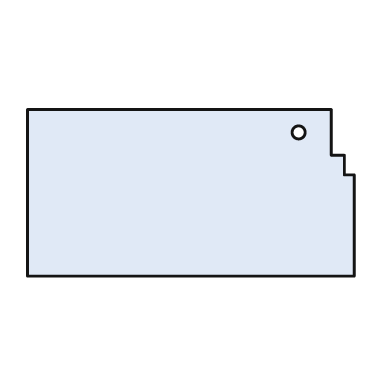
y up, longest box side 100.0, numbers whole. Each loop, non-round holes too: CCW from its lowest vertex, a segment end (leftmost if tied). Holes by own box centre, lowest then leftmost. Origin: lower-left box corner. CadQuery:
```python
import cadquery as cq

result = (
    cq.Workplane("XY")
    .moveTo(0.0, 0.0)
    .lineTo(100.0, 0.0)
    .lineTo(100.0, 31.0)
    .lineTo(97.0, 31.0)
    .lineTo(97.0, 37.0)
    .lineTo(93.0, 37.0)
    .lineTo(93.0, 51.0)
    .lineTo(0.0, 51.0)
    .close()
    .moveTo(83.0, 44.0)
    .circle(2.0)
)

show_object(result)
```